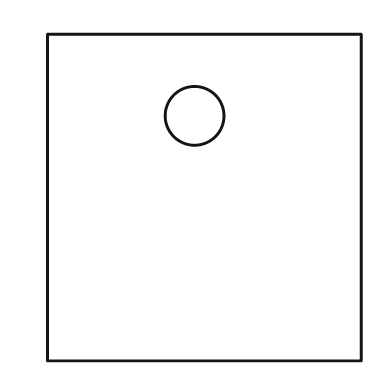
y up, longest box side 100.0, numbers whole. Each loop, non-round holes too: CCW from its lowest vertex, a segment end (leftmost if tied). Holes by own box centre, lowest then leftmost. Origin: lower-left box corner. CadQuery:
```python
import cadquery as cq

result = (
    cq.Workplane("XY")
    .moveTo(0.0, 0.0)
    .lineTo(96.0, 0.0)
    .lineTo(96.0, 100.0)
    .lineTo(0.0, 100.0)
    .close()
    .moveTo(45.0, 75.0)
    .circle(9.0)
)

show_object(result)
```